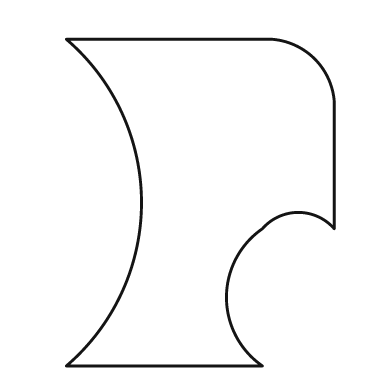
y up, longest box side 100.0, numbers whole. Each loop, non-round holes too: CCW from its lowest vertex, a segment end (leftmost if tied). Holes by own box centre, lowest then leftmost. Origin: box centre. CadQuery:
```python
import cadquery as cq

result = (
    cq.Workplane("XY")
    .moveTo(-41.0, -50.0)
    .lineTo(19.0, -50.0)
    .threePointArc((8.0, -29.0), (19.0, -8.0))
    .threePointArc((30.0, -3.0), (41.0, -8.0))
    .lineTo(41.0, 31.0)
    .threePointArc((35.0, 44.0), (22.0, 50.0))
    .lineTo(-41.0, 50.0)
    .threePointArc((-18.0, 0.0), (-41.0, -50.0))
    .close()
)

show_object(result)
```